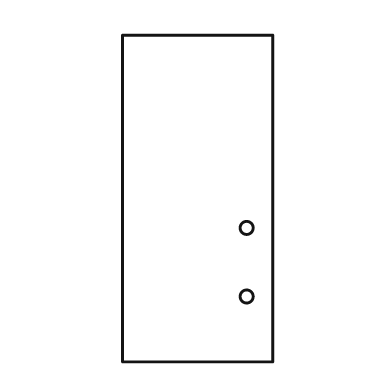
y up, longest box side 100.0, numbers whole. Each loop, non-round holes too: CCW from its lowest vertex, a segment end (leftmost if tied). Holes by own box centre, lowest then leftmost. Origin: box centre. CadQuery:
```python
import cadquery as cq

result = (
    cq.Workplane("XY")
    .moveTo(-23.0, -50.0)
    .lineTo(23.0, -50.0)
    .lineTo(23.0, 50.0)
    .lineTo(-23.0, 50.0)
    .close()
    .moveTo(15.0, -30.0)
    .circle(2.0)
    .moveTo(15.0, -9.0)
    .circle(2.0)
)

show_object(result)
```